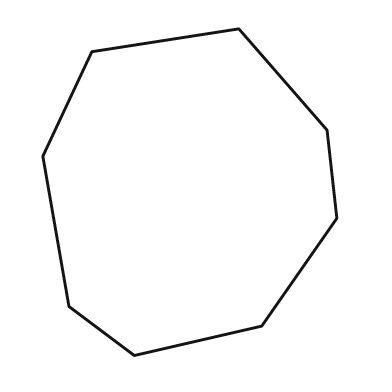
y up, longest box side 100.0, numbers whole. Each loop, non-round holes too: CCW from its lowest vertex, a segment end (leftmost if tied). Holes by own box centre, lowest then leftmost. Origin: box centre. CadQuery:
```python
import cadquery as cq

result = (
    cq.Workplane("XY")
    .moveTo(-17.0, -50.0)
    .lineTo(22.0, -41.0)
    .lineTo(45.0, -8.0)
    .lineTo(42.0, 19.0)
    .lineTo(15.0, 50.0)
    .lineTo(-30.0, 43.0)
    .lineTo(-45.0, 11.0)
    .lineTo(-37.0, -35.0)
    .close()
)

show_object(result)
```